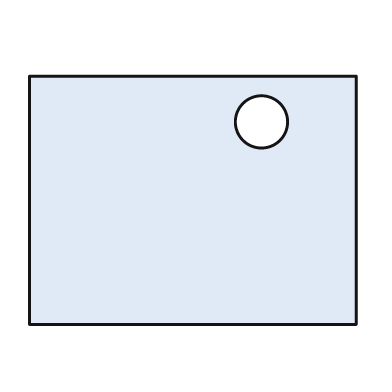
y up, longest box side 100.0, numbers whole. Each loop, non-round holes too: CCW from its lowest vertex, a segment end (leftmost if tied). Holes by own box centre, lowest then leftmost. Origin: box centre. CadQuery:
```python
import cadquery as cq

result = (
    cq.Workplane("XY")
    .moveTo(-50.0, -38.0)
    .lineTo(50.0, -38.0)
    .lineTo(50.0, 38.0)
    .lineTo(-50.0, 38.0)
    .close()
    .moveTo(21.0, 24.0)
    .circle(8.0)
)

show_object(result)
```